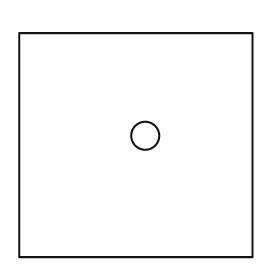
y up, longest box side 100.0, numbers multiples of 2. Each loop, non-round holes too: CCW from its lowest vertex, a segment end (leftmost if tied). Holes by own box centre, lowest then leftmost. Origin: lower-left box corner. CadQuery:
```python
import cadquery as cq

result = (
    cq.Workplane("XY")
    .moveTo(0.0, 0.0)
    .lineTo(100.0, 0.0)
    .lineTo(100.0, 96.0)
    .lineTo(0.0, 96.0)
    .close()
    .moveTo(54.0, 52.0)
    .circle(6.0)
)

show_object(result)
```